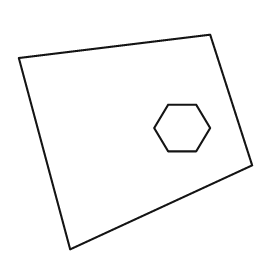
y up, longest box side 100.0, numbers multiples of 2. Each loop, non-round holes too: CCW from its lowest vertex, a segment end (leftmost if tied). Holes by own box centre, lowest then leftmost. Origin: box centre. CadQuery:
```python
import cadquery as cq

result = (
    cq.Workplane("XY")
    .moveTo(-28.0, -46.0)
    .lineTo(50.0, -10.0)
    .lineTo(32.0, 46.0)
    .lineTo(-50.0, 36.0)
    .close()
    .moveTo(14.0, -4.0)
    .lineTo(26.0, -4.0)
    .lineTo(32.0, 6.0)
    .lineTo(26.0, 16.0)
    .lineTo(14.0, 16.0)
    .lineTo(8.0, 6.0)
    .close()
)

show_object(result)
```